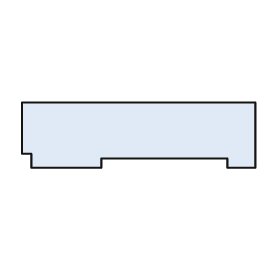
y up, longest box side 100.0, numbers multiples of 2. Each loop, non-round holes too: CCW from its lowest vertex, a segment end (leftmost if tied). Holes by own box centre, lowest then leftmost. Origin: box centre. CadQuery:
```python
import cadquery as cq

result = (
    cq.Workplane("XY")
    .moveTo(-46.0, -14.0)
    .lineTo(-16.0, -14.0)
    .lineTo(-16.0, -10.0)
    .lineTo(38.0, -10.0)
    .lineTo(38.0, -14.0)
    .lineTo(50.0, -14.0)
    .lineTo(50.0, 14.0)
    .lineTo(-50.0, 14.0)
    .lineTo(-50.0, -8.0)
    .lineTo(-46.0, -8.0)
    .close()
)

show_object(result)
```